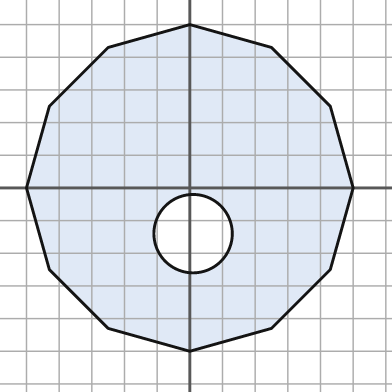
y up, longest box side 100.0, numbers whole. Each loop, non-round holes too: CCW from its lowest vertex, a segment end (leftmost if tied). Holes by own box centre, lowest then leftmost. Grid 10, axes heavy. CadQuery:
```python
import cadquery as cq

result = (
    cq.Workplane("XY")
    .moveTo(0.0, -50.0)
    .lineTo(25.0, -43.0)
    .lineTo(43.0, -25.0)
    .lineTo(50.0, 0.0)
    .lineTo(43.0, 25.0)
    .lineTo(25.0, 43.0)
    .lineTo(0.0, 50.0)
    .lineTo(-25.0, 43.0)
    .lineTo(-43.0, 25.0)
    .lineTo(-50.0, 0.0)
    .lineTo(-43.0, -25.0)
    .lineTo(-25.0, -43.0)
    .close()
    .moveTo(1.0, -14.0)
    .circle(12.0)
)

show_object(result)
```